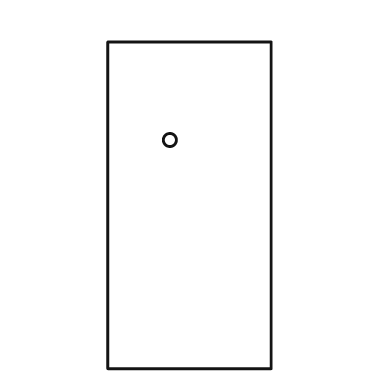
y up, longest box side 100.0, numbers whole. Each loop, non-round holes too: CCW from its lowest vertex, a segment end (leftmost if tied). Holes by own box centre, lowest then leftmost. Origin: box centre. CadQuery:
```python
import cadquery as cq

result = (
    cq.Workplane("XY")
    .moveTo(-25.0, -50.0)
    .lineTo(25.0, -50.0)
    .lineTo(25.0, 50.0)
    .lineTo(-25.0, 50.0)
    .close()
    .moveTo(-6.0, 20.0)
    .circle(2.0)
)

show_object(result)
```